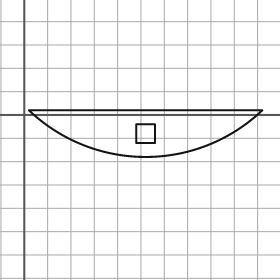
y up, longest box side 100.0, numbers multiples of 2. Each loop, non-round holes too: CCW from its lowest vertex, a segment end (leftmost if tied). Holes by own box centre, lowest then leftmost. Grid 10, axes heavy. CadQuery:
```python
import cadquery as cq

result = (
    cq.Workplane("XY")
    .moveTo(2.0, 2.0)
    .threePointArc((52.0, -18.0), (102.0, 2.0))
    .close()
    .moveTo(48.0, -12.0)
    .lineTo(56.0, -12.0)
    .lineTo(56.0, -4.0)
    .lineTo(48.0, -4.0)
    .close()
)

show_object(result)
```